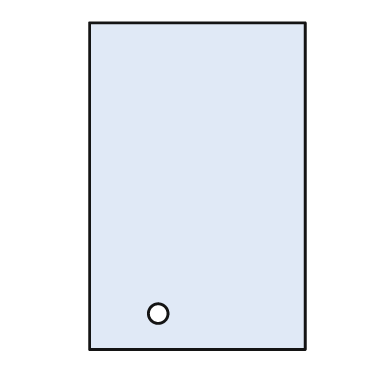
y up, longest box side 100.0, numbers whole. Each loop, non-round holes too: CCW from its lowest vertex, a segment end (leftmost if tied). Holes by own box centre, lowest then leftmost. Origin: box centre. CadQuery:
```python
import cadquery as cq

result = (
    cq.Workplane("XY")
    .moveTo(-33.0, -50.0)
    .lineTo(33.0, -50.0)
    .lineTo(33.0, 50.0)
    .lineTo(-33.0, 50.0)
    .close()
    .moveTo(-12.0, -39.0)
    .circle(3.0)
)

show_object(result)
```